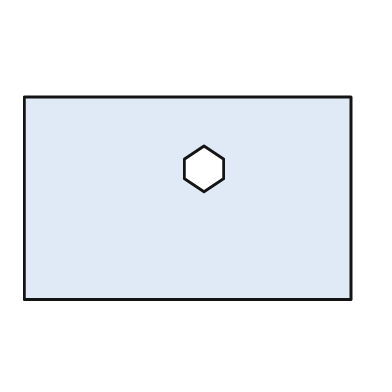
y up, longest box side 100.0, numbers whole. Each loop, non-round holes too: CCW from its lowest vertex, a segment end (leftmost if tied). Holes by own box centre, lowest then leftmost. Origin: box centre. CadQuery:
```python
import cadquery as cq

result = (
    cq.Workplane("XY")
    .moveTo(-50.0, -31.0)
    .lineTo(50.0, -31.0)
    .lineTo(50.0, 31.0)
    .lineTo(-50.0, 31.0)
    .close()
    .moveTo(5.0, 2.0)
    .lineTo(11.0, 6.0)
    .lineTo(11.0, 12.0)
    .lineTo(5.0, 16.0)
    .lineTo(-1.0, 12.0)
    .lineTo(-1.0, 6.0)
    .close()
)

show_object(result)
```